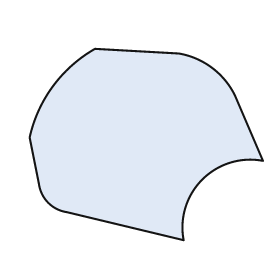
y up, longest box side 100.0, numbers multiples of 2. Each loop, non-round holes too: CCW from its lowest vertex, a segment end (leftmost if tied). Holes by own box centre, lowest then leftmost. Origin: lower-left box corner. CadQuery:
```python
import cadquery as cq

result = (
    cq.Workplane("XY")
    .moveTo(66.0, 0.0)
    .threePointArc((74.0, 26.0), (100.0, 34.0))
    .lineTo(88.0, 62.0)
    .threePointArc((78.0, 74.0), (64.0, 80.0))
    .lineTo(28.0, 82.0)
    .threePointArc((10.0, 66.0), (0.0, 44.0))
    .lineTo(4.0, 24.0)
    .threePointArc((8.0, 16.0), (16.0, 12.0))
    .close()
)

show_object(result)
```